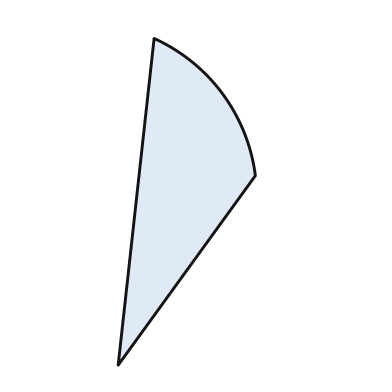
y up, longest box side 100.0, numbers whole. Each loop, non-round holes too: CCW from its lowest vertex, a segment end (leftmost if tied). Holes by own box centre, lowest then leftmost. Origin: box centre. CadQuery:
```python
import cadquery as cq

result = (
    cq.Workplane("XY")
    .moveTo(-21.0, -50.0)
    .lineTo(21.0, 8.0)
    .threePointArc((11.0, 33.0), (-10.0, 50.0))
    .close()
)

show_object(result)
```